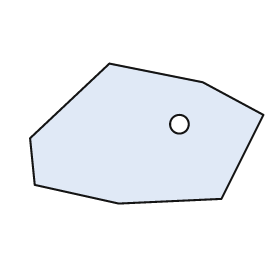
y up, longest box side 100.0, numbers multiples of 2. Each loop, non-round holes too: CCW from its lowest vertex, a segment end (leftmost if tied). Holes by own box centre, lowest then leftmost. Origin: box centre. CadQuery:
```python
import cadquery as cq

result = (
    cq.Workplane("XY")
    .moveTo(-12.0, -30.0)
    .lineTo(32.0, -28.0)
    .lineTo(50.0, 8.0)
    .lineTo(24.0, 22.0)
    .lineTo(-16.0, 30.0)
    .lineTo(-50.0, -2.0)
    .lineTo(-48.0, -22.0)
    .close()
    .moveTo(14.0, 4.0)
    .circle(4.0)
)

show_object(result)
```